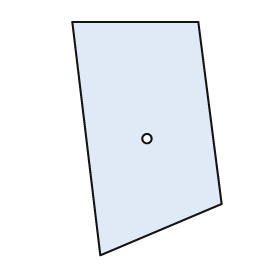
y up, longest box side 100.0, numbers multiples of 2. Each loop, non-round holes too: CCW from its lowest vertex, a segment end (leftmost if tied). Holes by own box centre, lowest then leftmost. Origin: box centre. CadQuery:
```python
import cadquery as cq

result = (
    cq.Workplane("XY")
    .moveTo(-20.0, -50.0)
    .lineTo(32.0, -28.0)
    .lineTo(22.0, 50.0)
    .lineTo(-32.0, 50.0)
    .close()
    .moveTo(0.0, 0.0)
    .circle(2.0)
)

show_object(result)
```